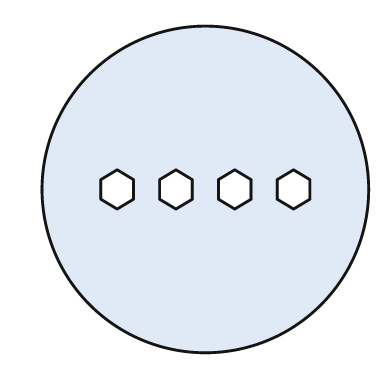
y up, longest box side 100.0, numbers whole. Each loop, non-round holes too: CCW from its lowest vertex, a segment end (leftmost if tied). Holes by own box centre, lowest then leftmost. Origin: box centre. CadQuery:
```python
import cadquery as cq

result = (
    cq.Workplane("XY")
    .moveTo(0.0, 0.0)
    .circle(50.0)
    .moveTo(-27.0, -6.0)
    .lineTo(-22.0, -3.0)
    .lineTo(-22.0, 3.0)
    .lineTo(-27.0, 6.0)
    .lineTo(-32.0, 3.0)
    .lineTo(-32.0, -3.0)
    .close()
    .moveTo(-9.0, -6.0)
    .lineTo(-4.0, -3.0)
    .lineTo(-4.0, 3.0)
    .lineTo(-9.0, 6.0)
    .lineTo(-14.0, 3.0)
    .lineTo(-14.0, -3.0)
    .close()
    .moveTo(9.0, -6.0)
    .lineTo(14.0, -3.0)
    .lineTo(14.0, 3.0)
    .lineTo(9.0, 6.0)
    .lineTo(4.0, 3.0)
    .lineTo(4.0, -3.0)
    .close()
    .moveTo(27.0, -6.0)
    .lineTo(32.0, -3.0)
    .lineTo(32.0, 3.0)
    .lineTo(27.0, 6.0)
    .lineTo(22.0, 3.0)
    .lineTo(22.0, -3.0)
    .close()
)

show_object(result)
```